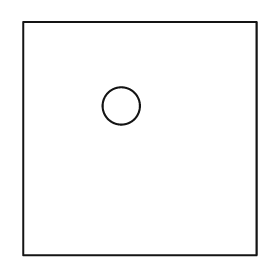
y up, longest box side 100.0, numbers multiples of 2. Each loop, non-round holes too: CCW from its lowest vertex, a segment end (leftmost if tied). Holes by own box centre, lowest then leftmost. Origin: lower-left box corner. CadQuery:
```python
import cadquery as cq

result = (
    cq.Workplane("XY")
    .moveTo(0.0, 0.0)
    .lineTo(100.0, 0.0)
    .lineTo(100.0, 100.0)
    .lineTo(0.0, 100.0)
    .close()
    .moveTo(42.0, 64.0)
    .circle(8.0)
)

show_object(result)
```